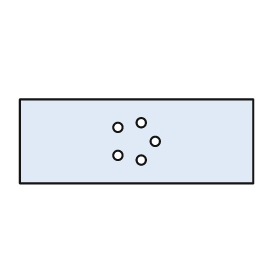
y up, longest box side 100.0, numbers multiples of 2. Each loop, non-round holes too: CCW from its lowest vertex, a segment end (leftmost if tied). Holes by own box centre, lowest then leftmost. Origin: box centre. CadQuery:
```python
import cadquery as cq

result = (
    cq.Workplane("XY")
    .moveTo(-50.0, -18.0)
    .lineTo(50.0, -18.0)
    .lineTo(50.0, 18.0)
    .lineTo(-50.0, 18.0)
    .close()
    .moveTo(2.0, -8.0)
    .circle(2.0)
    .moveTo(-8.0, -6.0)
    .circle(2.0)
    .moveTo(8.0, 0.0)
    .circle(2.0)
    .moveTo(-8.0, 6.0)
    .circle(2.0)
    .moveTo(2.0, 8.0)
    .circle(2.0)
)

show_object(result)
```